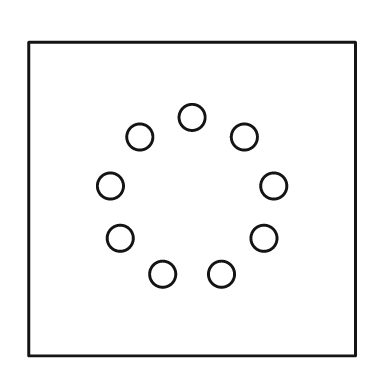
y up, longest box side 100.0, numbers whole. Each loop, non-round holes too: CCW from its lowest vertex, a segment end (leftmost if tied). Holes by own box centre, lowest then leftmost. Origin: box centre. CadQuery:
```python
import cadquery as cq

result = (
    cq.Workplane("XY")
    .moveTo(-50.0, -48.0)
    .lineTo(50.0, -48.0)
    .lineTo(50.0, 48.0)
    .lineTo(-50.0, 48.0)
    .close()
    .moveTo(-9.0, -23.0)
    .circle(4.0)
    .moveTo(9.0, -23.0)
    .circle(4.0)
    .moveTo(-22.0, -12.0)
    .circle(4.0)
    .moveTo(22.0, -12.0)
    .circle(4.0)
    .moveTo(-25.0, 4.0)
    .circle(4.0)
    .moveTo(25.0, 4.0)
    .circle(4.0)
    .moveTo(-16.0, 19.0)
    .circle(4.0)
    .moveTo(16.0, 19.0)
    .circle(4.0)
    .moveTo(0.0, 25.0)
    .circle(4.0)
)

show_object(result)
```